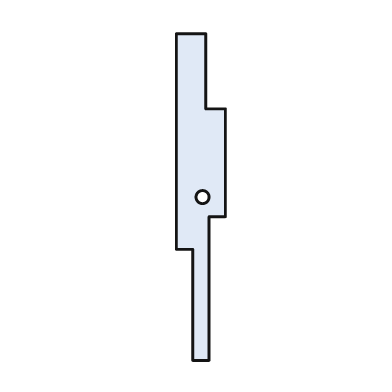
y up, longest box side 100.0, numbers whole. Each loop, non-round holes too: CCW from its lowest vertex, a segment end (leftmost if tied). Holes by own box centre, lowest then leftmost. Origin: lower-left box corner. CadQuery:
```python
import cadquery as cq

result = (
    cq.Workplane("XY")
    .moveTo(5.0, 0.0)
    .lineTo(10.0, 0.0)
    .lineTo(10.0, 44.0)
    .lineTo(15.0, 44.0)
    .lineTo(15.0, 77.0)
    .lineTo(9.0, 77.0)
    .lineTo(9.0, 100.0)
    .lineTo(0.0, 100.0)
    .lineTo(0.0, 34.0)
    .lineTo(5.0, 34.0)
    .close()
    .moveTo(8.0, 50.0)
    .circle(2.0)
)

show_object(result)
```